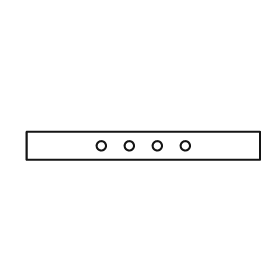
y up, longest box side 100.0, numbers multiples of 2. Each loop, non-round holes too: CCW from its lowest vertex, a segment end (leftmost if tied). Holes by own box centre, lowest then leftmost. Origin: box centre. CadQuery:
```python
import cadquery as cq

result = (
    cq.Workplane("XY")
    .moveTo(-50.0, -6.0)
    .lineTo(50.0, -6.0)
    .lineTo(50.0, 6.0)
    .lineTo(-50.0, 6.0)
    .close()
    .moveTo(-18.0, 0.0)
    .circle(2.0)
    .moveTo(-6.0, 0.0)
    .circle(2.0)
    .moveTo(6.0, 0.0)
    .circle(2.0)
    .moveTo(18.0, 0.0)
    .circle(2.0)
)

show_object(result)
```